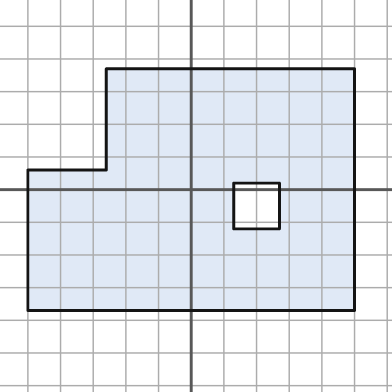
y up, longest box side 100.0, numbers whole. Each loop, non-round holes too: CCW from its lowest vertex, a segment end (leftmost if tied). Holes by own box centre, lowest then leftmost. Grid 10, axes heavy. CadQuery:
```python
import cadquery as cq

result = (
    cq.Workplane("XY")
    .moveTo(-50.0, -37.0)
    .lineTo(50.0, -37.0)
    .lineTo(50.0, 37.0)
    .lineTo(-26.0, 37.0)
    .lineTo(-26.0, 6.0)
    .lineTo(-50.0, 6.0)
    .close()
    .moveTo(13.0, -12.0)
    .lineTo(27.0, -12.0)
    .lineTo(27.0, 2.0)
    .lineTo(13.0, 2.0)
    .close()
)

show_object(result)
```